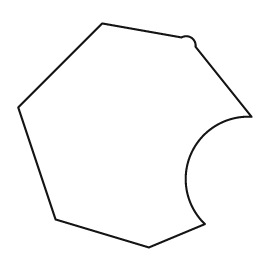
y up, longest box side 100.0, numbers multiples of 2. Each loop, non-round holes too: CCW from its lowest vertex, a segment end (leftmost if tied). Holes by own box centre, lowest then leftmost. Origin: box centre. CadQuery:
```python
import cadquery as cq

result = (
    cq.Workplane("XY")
    .moveTo(6.0, -48.0)
    .lineTo(30.0, -38.0)
    .threePointArc((24.0, -8.0), (50.0, 8.0))
    .lineTo(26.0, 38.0)
    .threePointArc((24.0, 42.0), (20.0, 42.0))
    .lineTo(-14.0, 48.0)
    .lineTo(-50.0, 12.0)
    .lineTo(-34.0, -36.0)
    .close()
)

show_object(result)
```